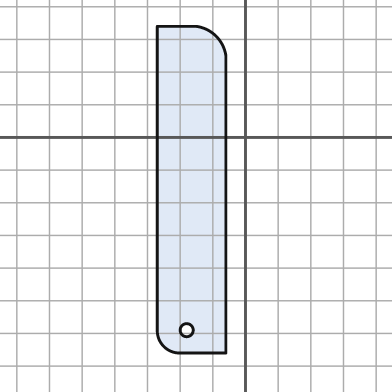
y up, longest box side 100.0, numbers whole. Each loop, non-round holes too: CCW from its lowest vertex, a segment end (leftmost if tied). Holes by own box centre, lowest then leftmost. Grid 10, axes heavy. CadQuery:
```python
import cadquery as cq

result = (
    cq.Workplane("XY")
    .moveTo(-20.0, -66.0)
    .lineTo(-6.0, -66.0)
    .lineTo(-6.0, 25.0)
    .threePointArc((-9.0, 31.0), (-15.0, 34.0))
    .lineTo(-27.0, 34.0)
    .lineTo(-27.0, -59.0)
    .threePointArc((-25.0, -64.0), (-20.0, -66.0))
    .close()
    .moveTo(-18.0, -59.0)
    .circle(2.0)
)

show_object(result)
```